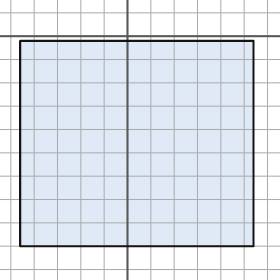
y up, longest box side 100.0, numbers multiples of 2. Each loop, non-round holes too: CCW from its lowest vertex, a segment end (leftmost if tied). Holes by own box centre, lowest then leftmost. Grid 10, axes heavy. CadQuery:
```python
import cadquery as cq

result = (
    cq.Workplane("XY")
    .moveTo(-46.0, -90.0)
    .lineTo(54.0, -90.0)
    .lineTo(54.0, -2.0)
    .lineTo(-46.0, -2.0)
    .close()
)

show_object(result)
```